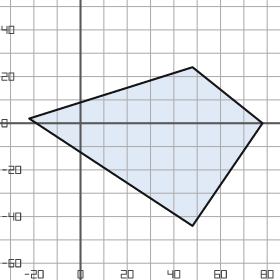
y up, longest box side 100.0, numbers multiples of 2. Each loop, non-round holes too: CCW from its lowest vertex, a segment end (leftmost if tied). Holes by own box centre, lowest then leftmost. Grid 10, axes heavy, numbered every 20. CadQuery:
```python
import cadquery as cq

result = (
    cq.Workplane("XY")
    .moveTo(48.0, -44.0)
    .lineTo(78.0, 0.0)
    .lineTo(48.0, 24.0)
    .lineTo(-22.0, 2.0)
    .close()
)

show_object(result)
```